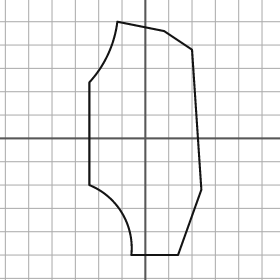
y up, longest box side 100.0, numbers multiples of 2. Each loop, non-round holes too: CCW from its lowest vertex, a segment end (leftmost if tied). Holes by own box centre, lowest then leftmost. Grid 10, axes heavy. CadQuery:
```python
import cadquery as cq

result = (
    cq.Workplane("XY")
    .moveTo(-6.0, -50.0)
    .lineTo(14.0, -50.0)
    .lineTo(24.0, -22.0)
    .lineTo(20.0, 38.0)
    .lineTo(8.0, 46.0)
    .lineTo(-12.0, 50.0)
    .threePointArc((-16.0, 36.0), (-24.0, 24.0))
    .lineTo(-24.0, -20.0)
    .threePointArc((-10.0, -32.0), (-6.0, -50.0))
    .close()
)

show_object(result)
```